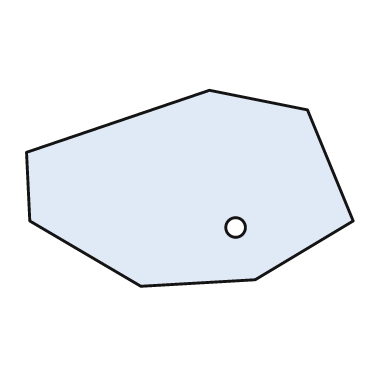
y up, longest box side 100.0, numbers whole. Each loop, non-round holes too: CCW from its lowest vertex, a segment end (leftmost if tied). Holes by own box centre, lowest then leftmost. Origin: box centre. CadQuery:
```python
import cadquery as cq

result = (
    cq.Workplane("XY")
    .moveTo(-15.0, -30.0)
    .lineTo(20.0, -28.0)
    .lineTo(50.0, -10.0)
    .lineTo(36.0, 24.0)
    .lineTo(6.0, 30.0)
    .lineTo(-50.0, 11.0)
    .lineTo(-49.0, -10.0)
    .close()
    .moveTo(14.0, -12.0)
    .circle(3.0)
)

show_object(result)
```